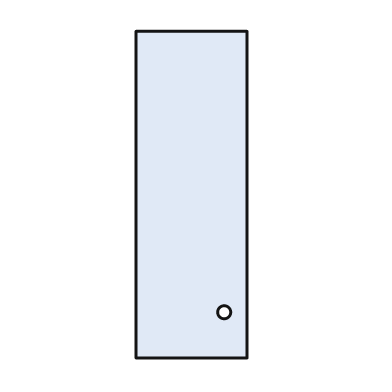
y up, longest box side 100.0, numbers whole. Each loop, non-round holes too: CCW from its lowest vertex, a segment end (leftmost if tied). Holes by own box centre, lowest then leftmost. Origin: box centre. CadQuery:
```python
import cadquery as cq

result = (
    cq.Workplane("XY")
    .moveTo(-17.0, -50.0)
    .lineTo(17.0, -50.0)
    .lineTo(17.0, 50.0)
    .lineTo(-17.0, 50.0)
    .close()
    .moveTo(10.0, -36.0)
    .circle(2.0)
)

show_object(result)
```